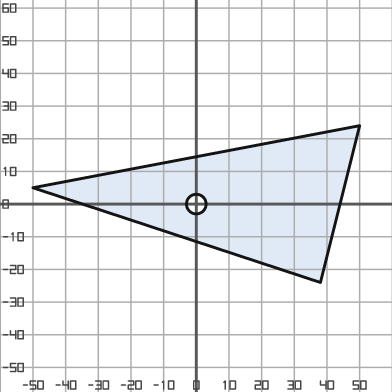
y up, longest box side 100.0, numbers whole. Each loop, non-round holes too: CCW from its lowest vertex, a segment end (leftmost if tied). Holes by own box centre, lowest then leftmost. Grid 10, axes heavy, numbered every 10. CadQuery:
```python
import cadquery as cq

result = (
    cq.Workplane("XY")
    .moveTo(38.0, -24.0)
    .lineTo(50.0, 24.0)
    .lineTo(-50.0, 5.0)
    .close()
    .moveTo(0.0, 0.0)
    .circle(3.0)
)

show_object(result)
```